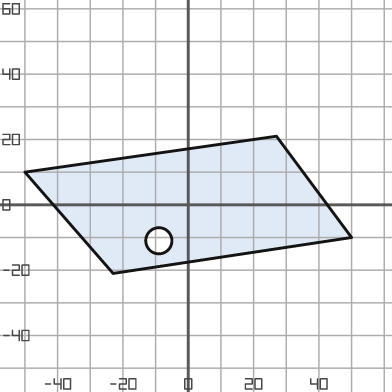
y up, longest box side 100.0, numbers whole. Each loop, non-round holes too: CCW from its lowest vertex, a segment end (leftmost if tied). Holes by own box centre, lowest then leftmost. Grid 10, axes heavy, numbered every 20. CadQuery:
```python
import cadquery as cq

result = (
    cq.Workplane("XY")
    .moveTo(-23.0, -21.0)
    .lineTo(50.0, -10.0)
    .lineTo(27.0, 21.0)
    .lineTo(-50.0, 10.0)
    .close()
    .moveTo(-9.0, -11.0)
    .circle(4.0)
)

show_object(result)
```